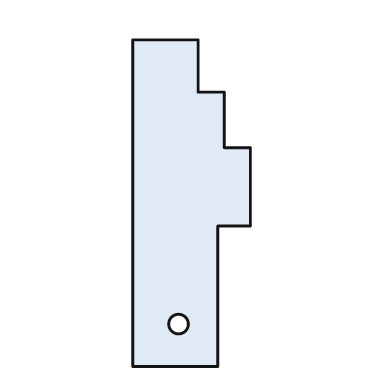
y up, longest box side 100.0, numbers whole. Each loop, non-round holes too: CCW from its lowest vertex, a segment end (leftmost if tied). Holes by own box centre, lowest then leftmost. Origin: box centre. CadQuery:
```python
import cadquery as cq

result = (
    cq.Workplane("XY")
    .moveTo(-18.0, -50.0)
    .lineTo(8.0, -50.0)
    .lineTo(8.0, -7.0)
    .lineTo(18.0, -7.0)
    .lineTo(18.0, 17.0)
    .lineTo(10.0, 17.0)
    .lineTo(10.0, 34.0)
    .lineTo(2.0, 34.0)
    .lineTo(2.0, 50.0)
    .lineTo(-18.0, 50.0)
    .close()
    .moveTo(-4.0, -37.0)
    .circle(3.0)
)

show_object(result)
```